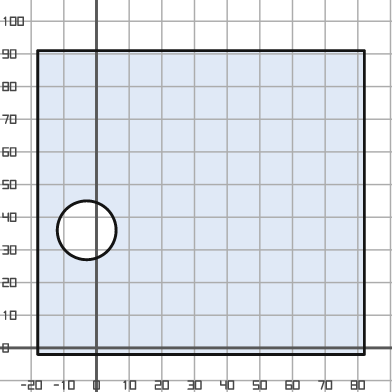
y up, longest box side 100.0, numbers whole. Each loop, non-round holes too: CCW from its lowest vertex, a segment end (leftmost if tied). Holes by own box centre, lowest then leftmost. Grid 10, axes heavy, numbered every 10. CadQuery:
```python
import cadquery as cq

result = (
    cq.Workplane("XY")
    .moveTo(-18.0, -2.0)
    .lineTo(82.0, -2.0)
    .lineTo(82.0, 91.0)
    .lineTo(-18.0, 91.0)
    .close()
    .moveTo(-3.0, 36.0)
    .circle(9.0)
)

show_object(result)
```